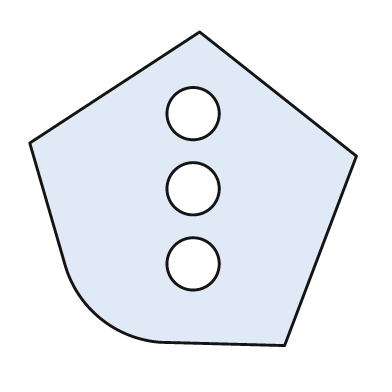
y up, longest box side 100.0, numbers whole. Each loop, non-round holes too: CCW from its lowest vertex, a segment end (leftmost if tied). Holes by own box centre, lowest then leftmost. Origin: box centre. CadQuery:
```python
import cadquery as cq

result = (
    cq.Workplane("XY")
    .moveTo(28.0, -48.0)
    .lineTo(50.0, 10.0)
    .lineTo(2.0, 48.0)
    .lineTo(-50.0, 14.0)
    .lineTo(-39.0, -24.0)
    .threePointArc((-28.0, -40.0), (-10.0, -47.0))
    .close()
    .moveTo(0.0, -23.0)
    .circle(8.0)
    .moveTo(0.0, 0.0)
    .circle(8.0)
    .moveTo(0.0, 23.0)
    .circle(8.0)
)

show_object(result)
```